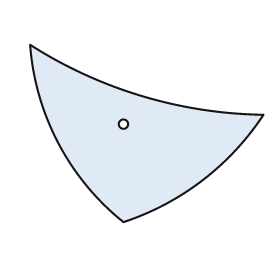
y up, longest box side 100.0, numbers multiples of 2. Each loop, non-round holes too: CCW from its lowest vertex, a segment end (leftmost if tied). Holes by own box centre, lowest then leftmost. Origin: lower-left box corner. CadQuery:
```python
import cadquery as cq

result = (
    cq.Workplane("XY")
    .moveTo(40.0, 0.0)
    .threePointArc((74.0, 18.0), (100.0, 46.0))
    .threePointArc((48.0, 54.0), (0.0, 76.0))
    .threePointArc((12.0, 34.0), (40.0, 0.0))
    .close()
    .moveTo(40.0, 42.0)
    .circle(2.0)
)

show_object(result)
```